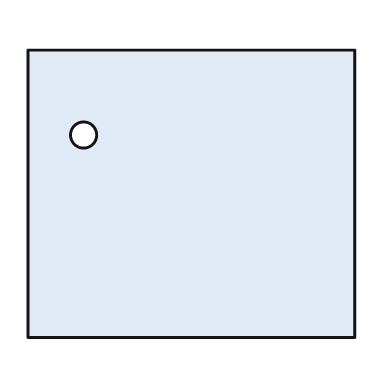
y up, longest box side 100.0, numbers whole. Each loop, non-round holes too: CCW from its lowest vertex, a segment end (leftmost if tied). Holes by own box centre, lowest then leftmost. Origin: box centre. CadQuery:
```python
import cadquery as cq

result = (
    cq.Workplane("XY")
    .moveTo(-50.0, -44.0)
    .lineTo(50.0, -44.0)
    .lineTo(50.0, 44.0)
    .lineTo(-50.0, 44.0)
    .close()
    .moveTo(-33.0, 18.0)
    .circle(4.0)
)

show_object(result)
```